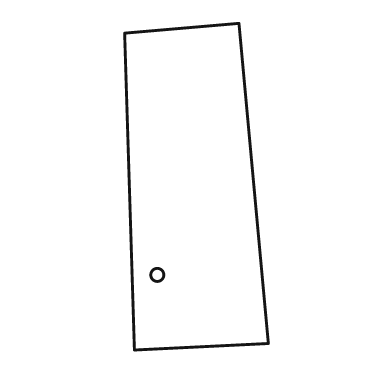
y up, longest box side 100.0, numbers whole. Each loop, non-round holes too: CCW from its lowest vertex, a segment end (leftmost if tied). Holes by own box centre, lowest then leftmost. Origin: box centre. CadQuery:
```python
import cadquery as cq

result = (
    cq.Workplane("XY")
    .moveTo(-19.0, -50.0)
    .lineTo(22.0, -48.0)
    .lineTo(13.0, 50.0)
    .lineTo(-22.0, 47.0)
    .close()
    .moveTo(-12.0, -27.0)
    .circle(2.0)
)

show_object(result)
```